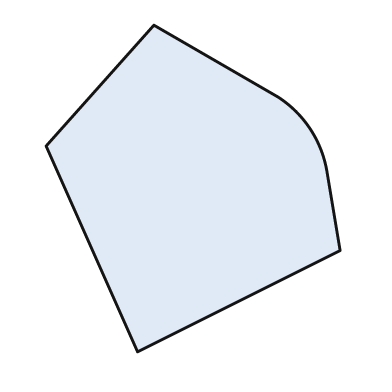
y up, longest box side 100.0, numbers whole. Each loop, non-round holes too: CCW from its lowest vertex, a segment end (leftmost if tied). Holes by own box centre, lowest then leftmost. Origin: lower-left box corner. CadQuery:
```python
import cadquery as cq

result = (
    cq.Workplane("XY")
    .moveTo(28.0, 0.0)
    .lineTo(90.0, 31.0)
    .lineTo(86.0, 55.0)
    .threePointArc((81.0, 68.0), (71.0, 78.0))
    .lineTo(33.0, 100.0)
    .lineTo(0.0, 63.0)
    .close()
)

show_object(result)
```